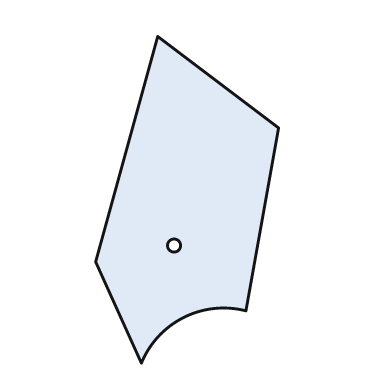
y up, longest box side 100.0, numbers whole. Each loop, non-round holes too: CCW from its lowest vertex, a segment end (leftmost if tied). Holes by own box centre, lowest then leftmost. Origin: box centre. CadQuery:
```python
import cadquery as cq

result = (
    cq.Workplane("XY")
    .moveTo(-14.0, -50.0)
    .threePointArc((-1.0, -36.0), (18.0, -34.0))
    .lineTo(28.0, 22.0)
    .lineTo(-9.0, 50.0)
    .lineTo(-28.0, -19.0)
    .close()
    .moveTo(-4.0, -14.0)
    .circle(2.0)
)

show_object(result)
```